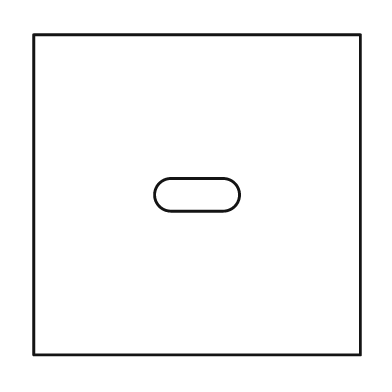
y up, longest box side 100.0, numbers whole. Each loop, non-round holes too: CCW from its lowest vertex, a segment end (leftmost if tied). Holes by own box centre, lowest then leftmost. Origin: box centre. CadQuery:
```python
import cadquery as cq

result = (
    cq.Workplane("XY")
    .moveTo(-50.0, -49.0)
    .lineTo(50.0, -49.0)
    .lineTo(50.0, 49.0)
    .lineTo(-50.0, 49.0)
    .close()
    .moveTo(-8.0, -5.0)
    .lineTo(8.0, -5.0)
    .threePointArc((13.0, 0.0), (8.0, 5.0))
    .lineTo(-8.0, 5.0)
    .threePointArc((-13.0, 0.0), (-8.0, -5.0))
    .close()
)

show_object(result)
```